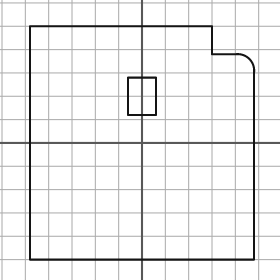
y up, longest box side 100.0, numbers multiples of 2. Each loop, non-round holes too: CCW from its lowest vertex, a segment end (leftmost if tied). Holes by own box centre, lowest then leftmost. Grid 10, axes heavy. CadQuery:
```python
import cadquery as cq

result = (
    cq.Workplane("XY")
    .moveTo(-48.0, -50.0)
    .lineTo(48.0, -50.0)
    .lineTo(48.0, 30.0)
    .threePointArc((46.0, 36.0), (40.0, 38.0))
    .lineTo(30.0, 38.0)
    .lineTo(30.0, 50.0)
    .lineTo(-48.0, 50.0)
    .close()
    .moveTo(-6.0, 12.0)
    .lineTo(6.0, 12.0)
    .lineTo(6.0, 28.0)
    .lineTo(-6.0, 28.0)
    .close()
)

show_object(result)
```